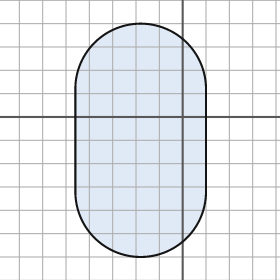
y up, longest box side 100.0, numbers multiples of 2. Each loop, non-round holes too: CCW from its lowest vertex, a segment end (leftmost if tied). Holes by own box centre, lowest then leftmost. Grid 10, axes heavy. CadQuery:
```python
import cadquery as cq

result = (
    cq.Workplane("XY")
    .moveTo(-46.0, -32.0)
    .threePointArc((-18.0, -60.0), (10.0, -32.0))
    .lineTo(10.0, 12.0)
    .threePointArc((-18.0, 40.0), (-46.0, 12.0))
    .close()
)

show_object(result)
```